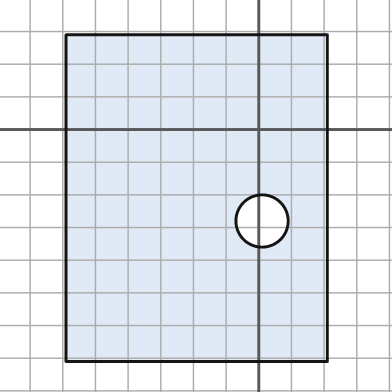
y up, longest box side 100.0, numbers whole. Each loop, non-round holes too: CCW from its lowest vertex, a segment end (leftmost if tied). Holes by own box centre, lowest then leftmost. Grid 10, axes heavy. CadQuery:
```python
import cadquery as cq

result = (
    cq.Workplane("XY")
    .moveTo(-59.0, -71.0)
    .lineTo(21.0, -71.0)
    .lineTo(21.0, 29.0)
    .lineTo(-59.0, 29.0)
    .close()
    .moveTo(1.0, -28.0)
    .circle(8.0)
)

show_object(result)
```